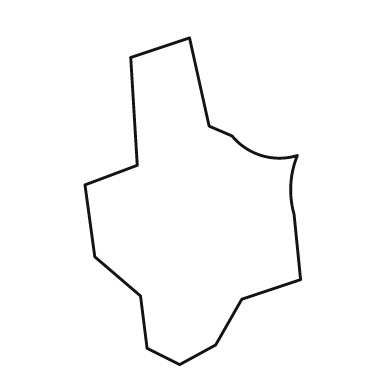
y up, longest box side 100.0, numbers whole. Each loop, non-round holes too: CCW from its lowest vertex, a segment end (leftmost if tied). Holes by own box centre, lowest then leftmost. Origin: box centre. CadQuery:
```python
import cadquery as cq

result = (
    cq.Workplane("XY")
    .moveTo(-4.0, -50.0)
    .lineTo(7.0, -44.0)
    .lineTo(15.0, -30.0)
    .lineTo(33.0, -24.0)
    .lineTo(31.0, -4.0)
    .threePointArc((30.0, 5.0), (32.0, 14.0))
    .threePointArc((21.0, 14.0), (12.0, 20.0))
    .lineTo(5.0, 23.0)
    .lineTo(-1.0, 50.0)
    .lineTo(-19.0, 44.0)
    .lineTo(-17.0, 11.0)
    .lineTo(-33.0, 5.0)
    .lineTo(-30.0, -17.0)
    .lineTo(-16.0, -29.0)
    .lineTo(-14.0, -45.0)
    .close()
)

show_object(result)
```